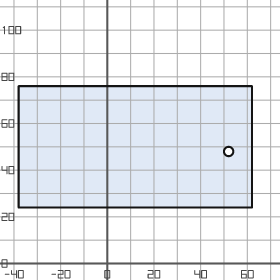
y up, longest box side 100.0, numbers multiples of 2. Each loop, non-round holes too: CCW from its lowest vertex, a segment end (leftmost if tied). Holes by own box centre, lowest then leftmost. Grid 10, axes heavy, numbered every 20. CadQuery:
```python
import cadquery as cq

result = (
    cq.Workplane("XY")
    .moveTo(-38.0, 24.0)
    .lineTo(62.0, 24.0)
    .lineTo(62.0, 76.0)
    .lineTo(-38.0, 76.0)
    .close()
    .moveTo(52.0, 48.0)
    .circle(2.0)
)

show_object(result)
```